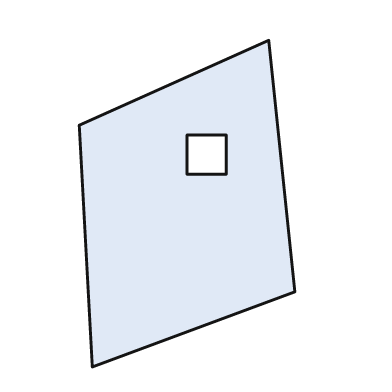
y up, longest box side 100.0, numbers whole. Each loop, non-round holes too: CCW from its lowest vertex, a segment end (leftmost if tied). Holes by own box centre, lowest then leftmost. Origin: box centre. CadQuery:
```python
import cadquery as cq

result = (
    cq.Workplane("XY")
    .moveTo(-29.0, -50.0)
    .lineTo(33.0, -27.0)
    .lineTo(25.0, 50.0)
    .lineTo(-33.0, 24.0)
    .close()
    .moveTo(0.0, 9.0)
    .lineTo(12.0, 9.0)
    .lineTo(12.0, 21.0)
    .lineTo(0.0, 21.0)
    .close()
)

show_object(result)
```